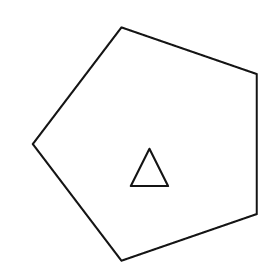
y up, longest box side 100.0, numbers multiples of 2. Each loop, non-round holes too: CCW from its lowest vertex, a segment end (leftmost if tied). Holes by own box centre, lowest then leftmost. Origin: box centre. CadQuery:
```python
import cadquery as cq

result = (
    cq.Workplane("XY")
    .moveTo(-10.0, -50.0)
    .lineTo(48.0, -30.0)
    .lineTo(48.0, 30.0)
    .lineTo(-10.0, 50.0)
    .lineTo(-48.0, 0.0)
    .close()
    .moveTo(-6.0, -18.0)
    .lineTo(10.0, -18.0)
    .lineTo(2.0, -2.0)
    .close()
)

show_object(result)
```